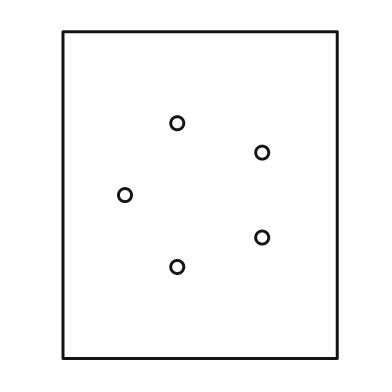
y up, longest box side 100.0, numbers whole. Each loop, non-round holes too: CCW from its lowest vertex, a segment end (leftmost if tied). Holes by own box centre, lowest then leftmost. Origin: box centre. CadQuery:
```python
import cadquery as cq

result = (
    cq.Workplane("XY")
    .moveTo(-42.0, -50.0)
    .lineTo(42.0, -50.0)
    .lineTo(42.0, 50.0)
    .lineTo(-42.0, 50.0)
    .close()
    .moveTo(-7.0, -22.0)
    .circle(2.0)
    .moveTo(19.0, -13.0)
    .circle(2.0)
    .moveTo(-23.0, 0.0)
    .circle(2.0)
    .moveTo(19.0, 13.0)
    .circle(2.0)
    .moveTo(-7.0, 22.0)
    .circle(2.0)
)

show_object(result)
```